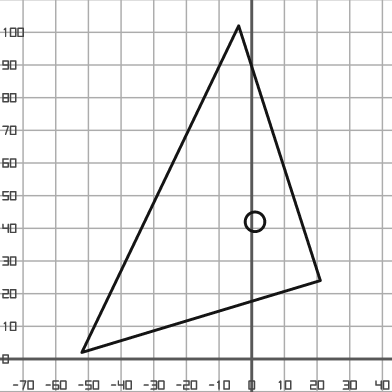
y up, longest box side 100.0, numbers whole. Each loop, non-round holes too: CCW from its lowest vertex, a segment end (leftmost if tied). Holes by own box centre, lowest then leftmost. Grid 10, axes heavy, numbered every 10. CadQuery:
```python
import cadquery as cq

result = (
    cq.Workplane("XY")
    .moveTo(-52.0, 2.0)
    .lineTo(21.0, 24.0)
    .lineTo(-4.0, 102.0)
    .close()
    .moveTo(1.0, 42.0)
    .circle(3.0)
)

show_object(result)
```